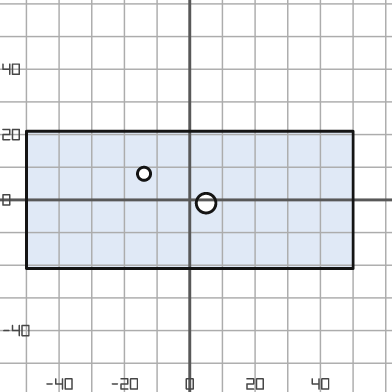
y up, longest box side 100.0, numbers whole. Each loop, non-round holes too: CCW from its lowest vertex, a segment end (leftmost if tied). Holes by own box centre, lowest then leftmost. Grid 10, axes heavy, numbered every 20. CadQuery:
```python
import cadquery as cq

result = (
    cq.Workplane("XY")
    .moveTo(-50.0, -21.0)
    .lineTo(50.0, -21.0)
    .lineTo(50.0, 21.0)
    .lineTo(-50.0, 21.0)
    .close()
    .moveTo(5.0, -1.0)
    .circle(3.0)
    .moveTo(-14.0, 8.0)
    .circle(2.0)
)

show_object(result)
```